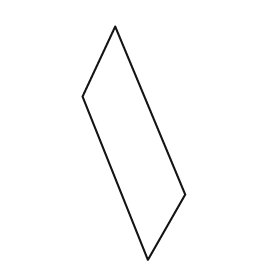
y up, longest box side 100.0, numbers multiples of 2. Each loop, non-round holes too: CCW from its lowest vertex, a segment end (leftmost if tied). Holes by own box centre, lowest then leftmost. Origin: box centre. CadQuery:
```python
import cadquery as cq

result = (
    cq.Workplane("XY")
    .moveTo(6.0, -50.0)
    .lineTo(22.0, -22.0)
    .lineTo(-8.0, 50.0)
    .lineTo(-22.0, 20.0)
    .close()
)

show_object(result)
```